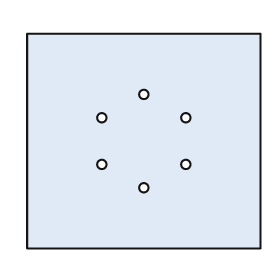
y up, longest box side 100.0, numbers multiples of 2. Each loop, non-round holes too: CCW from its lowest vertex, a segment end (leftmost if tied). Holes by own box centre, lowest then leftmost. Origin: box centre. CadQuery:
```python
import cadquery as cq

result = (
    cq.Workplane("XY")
    .moveTo(-50.0, -46.0)
    .lineTo(50.0, -46.0)
    .lineTo(50.0, 46.0)
    .lineTo(-50.0, 46.0)
    .close()
    .moveTo(0.0, -20.0)
    .circle(2.0)
    .moveTo(-18.0, -10.0)
    .circle(2.0)
    .moveTo(18.0, -10.0)
    .circle(2.0)
    .moveTo(-18.0, 10.0)
    .circle(2.0)
    .moveTo(18.0, 10.0)
    .circle(2.0)
    .moveTo(0.0, 20.0)
    .circle(2.0)
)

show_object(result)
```